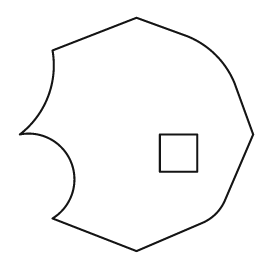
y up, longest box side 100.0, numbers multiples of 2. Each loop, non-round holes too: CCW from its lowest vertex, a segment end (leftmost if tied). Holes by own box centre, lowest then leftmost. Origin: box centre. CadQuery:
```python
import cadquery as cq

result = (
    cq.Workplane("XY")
    .moveTo(0.0, -50.0)
    .lineTo(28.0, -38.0)
    .threePointArc((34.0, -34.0), (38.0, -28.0))
    .lineTo(50.0, 0.0)
    .lineTo(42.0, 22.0)
    .threePointArc((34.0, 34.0), (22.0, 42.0))
    .lineTo(0.0, 50.0)
    .lineTo(-36.0, 36.0)
    .threePointArc((-38.0, 16.0), (-50.0, 0.0))
    .threePointArc((-28.0, -12.0), (-36.0, -36.0))
    .close()
    .moveTo(10.0, -16.0)
    .lineTo(26.0, -16.0)
    .lineTo(26.0, 0.0)
    .lineTo(10.0, 0.0)
    .close()
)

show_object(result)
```